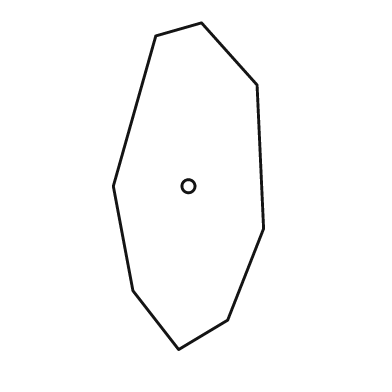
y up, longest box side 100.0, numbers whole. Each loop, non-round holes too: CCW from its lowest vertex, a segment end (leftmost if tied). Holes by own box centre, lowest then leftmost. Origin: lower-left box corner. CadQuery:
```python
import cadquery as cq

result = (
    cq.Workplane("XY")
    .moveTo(20.0, 0.0)
    .lineTo(35.0, 9.0)
    .lineTo(46.0, 37.0)
    .lineTo(44.0, 81.0)
    .lineTo(27.0, 100.0)
    .lineTo(13.0, 96.0)
    .lineTo(0.0, 50.0)
    .lineTo(6.0, 18.0)
    .close()
    .moveTo(23.0, 50.0)
    .circle(2.0)
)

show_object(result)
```